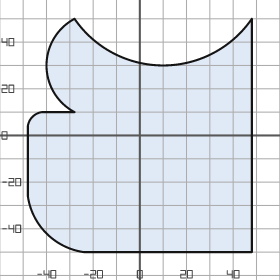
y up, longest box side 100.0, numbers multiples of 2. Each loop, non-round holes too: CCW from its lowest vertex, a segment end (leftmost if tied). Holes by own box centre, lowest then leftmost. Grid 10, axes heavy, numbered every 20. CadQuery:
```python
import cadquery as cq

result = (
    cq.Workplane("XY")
    .moveTo(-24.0, -50.0)
    .lineTo(48.0, -50.0)
    .lineTo(48.0, 50.0)
    .threePointArc((10.0, 30.0), (-28.0, 50.0))
    .threePointArc((-40.0, 30.0), (-28.0, 10.0))
    .lineTo(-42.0, 10.0)
    .threePointArc((-46.0, 8.0), (-48.0, 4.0))
    .lineTo(-48.0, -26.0)
    .threePointArc((-40.0, -42.0), (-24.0, -50.0))
    .close()
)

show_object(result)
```